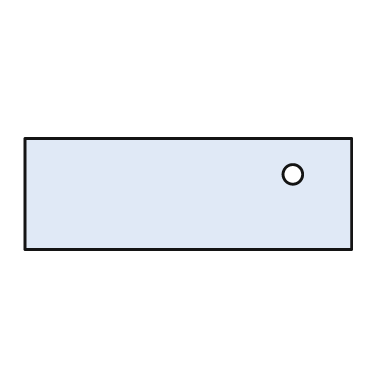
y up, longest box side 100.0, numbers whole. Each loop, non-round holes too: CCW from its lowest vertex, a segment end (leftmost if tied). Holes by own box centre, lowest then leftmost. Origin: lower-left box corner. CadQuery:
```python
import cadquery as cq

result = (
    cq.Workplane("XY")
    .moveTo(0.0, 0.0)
    .lineTo(100.0, 0.0)
    .lineTo(100.0, 34.0)
    .lineTo(0.0, 34.0)
    .close()
    .moveTo(82.0, 23.0)
    .circle(3.0)
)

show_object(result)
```